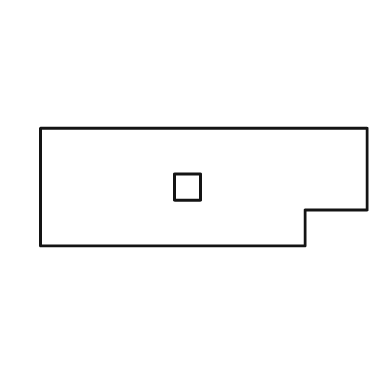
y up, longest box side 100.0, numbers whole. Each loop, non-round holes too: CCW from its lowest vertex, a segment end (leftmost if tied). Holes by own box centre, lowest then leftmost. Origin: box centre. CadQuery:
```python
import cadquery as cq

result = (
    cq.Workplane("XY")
    .moveTo(-50.0, -18.0)
    .lineTo(31.0, -18.0)
    .lineTo(31.0, -7.0)
    .lineTo(50.0, -7.0)
    .lineTo(50.0, 18.0)
    .lineTo(-50.0, 18.0)
    .close()
    .moveTo(-9.0, -4.0)
    .lineTo(-1.0, -4.0)
    .lineTo(-1.0, 4.0)
    .lineTo(-9.0, 4.0)
    .close()
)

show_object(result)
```